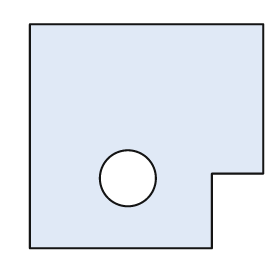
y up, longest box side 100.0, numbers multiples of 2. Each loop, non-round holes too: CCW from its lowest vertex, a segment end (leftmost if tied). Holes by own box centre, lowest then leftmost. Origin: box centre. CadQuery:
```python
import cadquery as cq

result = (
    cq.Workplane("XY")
    .moveTo(-50.0, -48.0)
    .lineTo(28.0, -48.0)
    .lineTo(28.0, -16.0)
    .lineTo(50.0, -16.0)
    .lineTo(50.0, 48.0)
    .lineTo(-50.0, 48.0)
    .close()
    .moveTo(-8.0, -18.0)
    .circle(12.0)
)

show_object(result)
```